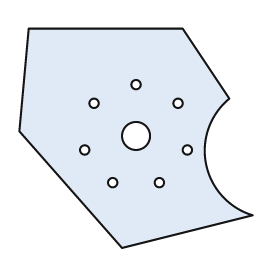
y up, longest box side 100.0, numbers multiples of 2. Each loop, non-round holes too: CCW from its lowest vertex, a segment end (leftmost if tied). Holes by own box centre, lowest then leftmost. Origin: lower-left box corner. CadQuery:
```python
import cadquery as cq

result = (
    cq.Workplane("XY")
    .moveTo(44.0, 0.0)
    .lineTo(100.0, 14.0)
    .threePointArc((80.0, 36.0), (90.0, 64.0))
    .lineTo(70.0, 94.0)
    .lineTo(4.0, 94.0)
    .lineTo(0.0, 50.0)
    .close()
    .moveTo(40.0, 28.0)
    .circle(2.0)
    .moveTo(60.0, 28.0)
    .circle(2.0)
    .moveTo(28.0, 42.0)
    .circle(2.0)
    .moveTo(72.0, 42.0)
    .circle(2.0)
    .moveTo(50.0, 48.0)
    .circle(6.0)
    .moveTo(32.0, 62.0)
    .circle(2.0)
    .moveTo(68.0, 62.0)
    .circle(2.0)
    .moveTo(50.0, 70.0)
    .circle(2.0)
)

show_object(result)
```